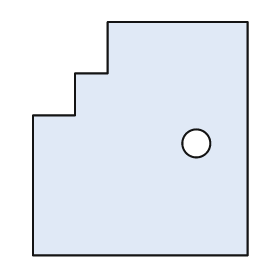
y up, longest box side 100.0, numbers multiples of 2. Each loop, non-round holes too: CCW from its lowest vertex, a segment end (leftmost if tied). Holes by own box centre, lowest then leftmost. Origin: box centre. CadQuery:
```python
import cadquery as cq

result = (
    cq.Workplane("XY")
    .moveTo(-46.0, -50.0)
    .lineTo(46.0, -50.0)
    .lineTo(46.0, 50.0)
    .lineTo(-14.0, 50.0)
    .lineTo(-14.0, 28.0)
    .lineTo(-28.0, 28.0)
    .lineTo(-28.0, 10.0)
    .lineTo(-46.0, 10.0)
    .close()
    .moveTo(24.0, -2.0)
    .circle(6.0)
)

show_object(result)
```